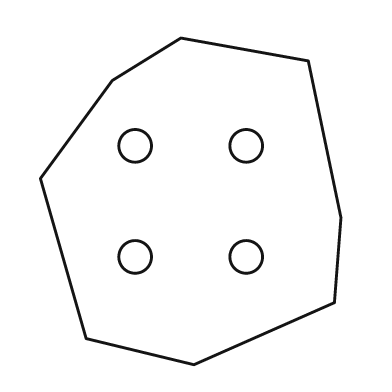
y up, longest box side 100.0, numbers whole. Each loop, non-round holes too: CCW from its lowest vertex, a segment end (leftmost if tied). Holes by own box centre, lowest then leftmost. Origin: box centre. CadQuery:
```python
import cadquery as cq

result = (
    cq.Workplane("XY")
    .moveTo(1.0, -50.0)
    .lineTo(44.0, -31.0)
    .lineTo(46.0, -5.0)
    .lineTo(36.0, 43.0)
    .lineTo(-3.0, 50.0)
    .lineTo(-24.0, 37.0)
    .lineTo(-46.0, 7.0)
    .lineTo(-32.0, -42.0)
    .close()
    .moveTo(-17.0, -17.0)
    .circle(5.0)
    .moveTo(17.0, -17.0)
    .circle(5.0)
    .moveTo(-17.0, 17.0)
    .circle(5.0)
    .moveTo(17.0, 17.0)
    .circle(5.0)
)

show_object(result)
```